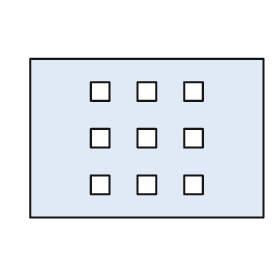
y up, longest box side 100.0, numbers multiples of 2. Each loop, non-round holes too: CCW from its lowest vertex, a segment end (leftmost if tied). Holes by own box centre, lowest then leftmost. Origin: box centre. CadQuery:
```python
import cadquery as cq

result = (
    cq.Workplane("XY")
    .moveTo(-50.0, -34.0)
    .lineTo(50.0, -34.0)
    .lineTo(50.0, 34.0)
    .lineTo(-50.0, 34.0)
    .close()
    .moveTo(-24.0, -24.0)
    .lineTo(-16.0, -24.0)
    .lineTo(-16.0, -16.0)
    .lineTo(-24.0, -16.0)
    .close()
    .moveTo(-4.0, -24.0)
    .lineTo(4.0, -24.0)
    .lineTo(4.0, -16.0)
    .lineTo(-4.0, -16.0)
    .close()
    .moveTo(16.0, -24.0)
    .lineTo(24.0, -24.0)
    .lineTo(24.0, -16.0)
    .lineTo(16.0, -16.0)
    .close()
    .moveTo(-24.0, -4.0)
    .lineTo(-16.0, -4.0)
    .lineTo(-16.0, 4.0)
    .lineTo(-24.0, 4.0)
    .close()
    .moveTo(-4.0, -4.0)
    .lineTo(4.0, -4.0)
    .lineTo(4.0, 4.0)
    .lineTo(-4.0, 4.0)
    .close()
    .moveTo(16.0, -4.0)
    .lineTo(24.0, -4.0)
    .lineTo(24.0, 4.0)
    .lineTo(16.0, 4.0)
    .close()
    .moveTo(-24.0, 16.0)
    .lineTo(-16.0, 16.0)
    .lineTo(-16.0, 24.0)
    .lineTo(-24.0, 24.0)
    .close()
    .moveTo(-4.0, 16.0)
    .lineTo(4.0, 16.0)
    .lineTo(4.0, 24.0)
    .lineTo(-4.0, 24.0)
    .close()
    .moveTo(16.0, 16.0)
    .lineTo(24.0, 16.0)
    .lineTo(24.0, 24.0)
    .lineTo(16.0, 24.0)
    .close()
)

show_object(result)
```